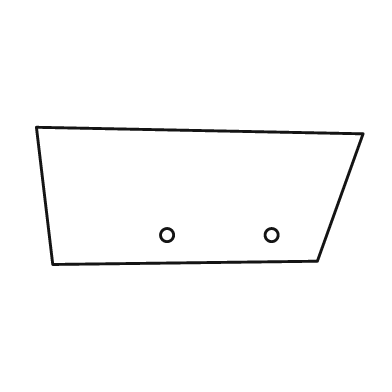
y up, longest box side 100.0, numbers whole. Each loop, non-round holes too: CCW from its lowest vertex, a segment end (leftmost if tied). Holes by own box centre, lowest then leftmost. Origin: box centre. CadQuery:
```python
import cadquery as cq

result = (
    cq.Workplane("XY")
    .moveTo(-45.0, -21.0)
    .lineTo(36.0, -20.0)
    .lineTo(50.0, 19.0)
    .lineTo(-50.0, 21.0)
    .close()
    .moveTo(-10.0, -12.0)
    .circle(2.0)
    .moveTo(22.0, -12.0)
    .circle(2.0)
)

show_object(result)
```